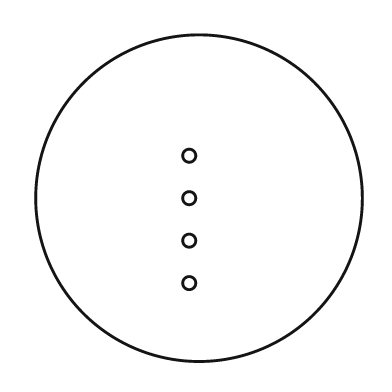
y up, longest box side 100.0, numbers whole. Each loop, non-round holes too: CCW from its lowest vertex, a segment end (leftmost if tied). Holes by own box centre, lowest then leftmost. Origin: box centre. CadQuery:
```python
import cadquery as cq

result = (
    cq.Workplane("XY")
    .moveTo(0.0, 0.0)
    .circle(50.0)
    .moveTo(-3.0, -26.0)
    .circle(2.0)
    .moveTo(-3.0, -13.0)
    .circle(2.0)
    .moveTo(-3.0, 0.0)
    .circle(2.0)
    .moveTo(-3.0, 13.0)
    .circle(2.0)
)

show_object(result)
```